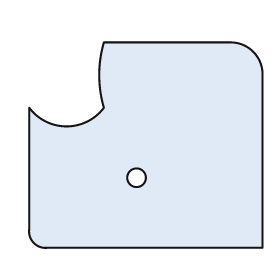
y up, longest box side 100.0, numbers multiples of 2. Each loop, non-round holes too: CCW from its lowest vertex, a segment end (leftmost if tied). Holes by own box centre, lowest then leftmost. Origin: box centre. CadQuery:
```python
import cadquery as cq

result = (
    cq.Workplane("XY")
    .moveTo(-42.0, -44.0)
    .lineTo(50.0, -44.0)
    .lineTo(50.0, 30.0)
    .threePointArc((46.0, 40.0), (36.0, 44.0))
    .lineTo(-18.0, 44.0)
    .threePointArc((-20.0, 30.0), (-18.0, 16.0))
    .threePointArc((-34.0, 8.0), (-50.0, 16.0))
    .lineTo(-50.0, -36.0)
    .threePointArc((-48.0, -42.0), (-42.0, -44.0))
    .close()
    .moveTo(-4.0, -14.0)
    .circle(4.0)
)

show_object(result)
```